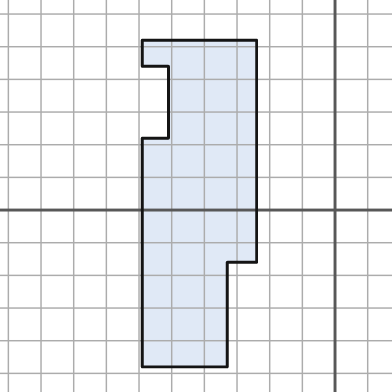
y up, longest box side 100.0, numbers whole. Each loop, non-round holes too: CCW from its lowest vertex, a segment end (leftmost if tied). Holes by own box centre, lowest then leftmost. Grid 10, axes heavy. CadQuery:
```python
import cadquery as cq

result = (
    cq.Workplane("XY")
    .moveTo(-59.0, -48.0)
    .lineTo(-33.0, -48.0)
    .lineTo(-33.0, -16.0)
    .lineTo(-24.0, -16.0)
    .lineTo(-24.0, 52.0)
    .lineTo(-59.0, 52.0)
    .lineTo(-59.0, 44.0)
    .lineTo(-51.0, 44.0)
    .lineTo(-51.0, 22.0)
    .lineTo(-59.0, 22.0)
    .close()
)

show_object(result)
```